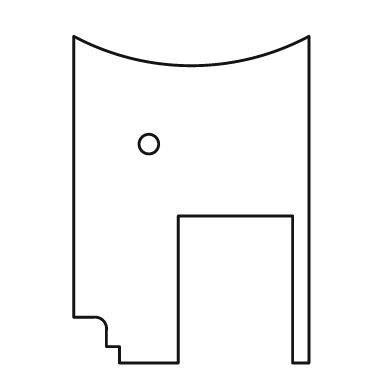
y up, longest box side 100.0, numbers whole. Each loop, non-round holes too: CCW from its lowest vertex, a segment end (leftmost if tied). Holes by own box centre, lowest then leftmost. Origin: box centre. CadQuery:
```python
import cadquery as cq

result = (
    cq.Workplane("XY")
    .moveTo(-22.0, -50.0)
    .lineTo(-4.0, -50.0)
    .lineTo(-4.0, -5.0)
    .lineTo(31.0, -5.0)
    .lineTo(31.0, -50.0)
    .lineTo(36.0, -50.0)
    .lineTo(36.0, 50.0)
    .threePointArc((0.0, 41.0), (-36.0, 50.0))
    .lineTo(-36.0, -36.0)
    .lineTo(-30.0, -36.0)
    .threePointArc((-27.0, -37.0), (-26.0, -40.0))
    .lineTo(-26.0, -45.0)
    .lineTo(-22.0, -45.0)
    .close()
    .moveTo(-13.0, 17.0)
    .circle(3.0)
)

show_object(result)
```